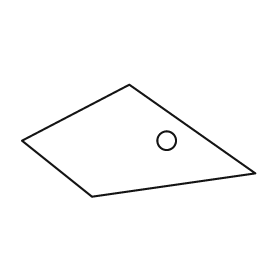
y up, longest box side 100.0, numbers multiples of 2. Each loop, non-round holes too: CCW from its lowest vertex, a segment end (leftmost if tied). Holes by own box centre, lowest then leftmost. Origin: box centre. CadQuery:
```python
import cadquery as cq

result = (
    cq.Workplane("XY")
    .moveTo(-20.0, -24.0)
    .lineTo(50.0, -14.0)
    .lineTo(-4.0, 24.0)
    .lineTo(-50.0, 0.0)
    .close()
    .moveTo(12.0, 0.0)
    .circle(4.0)
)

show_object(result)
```